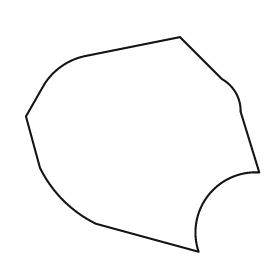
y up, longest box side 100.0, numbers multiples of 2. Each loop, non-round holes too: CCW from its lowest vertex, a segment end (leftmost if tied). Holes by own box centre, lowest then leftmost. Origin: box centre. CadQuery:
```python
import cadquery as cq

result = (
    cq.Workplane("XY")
    .moveTo(24.0, -46.0)
    .threePointArc((28.0, -22.0), (50.0, -12.0))
    .lineTo(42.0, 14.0)
    .threePointArc((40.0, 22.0), (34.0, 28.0))
    .lineTo(16.0, 46.0)
    .lineTo(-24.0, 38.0)
    .threePointArc((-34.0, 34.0), (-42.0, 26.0))
    .lineTo(-50.0, 12.0)
    .lineTo(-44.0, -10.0)
    .threePointArc((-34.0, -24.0), (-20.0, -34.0))
    .close()
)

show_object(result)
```